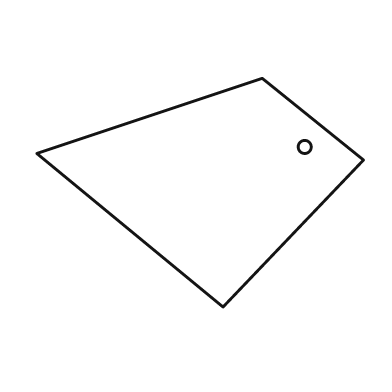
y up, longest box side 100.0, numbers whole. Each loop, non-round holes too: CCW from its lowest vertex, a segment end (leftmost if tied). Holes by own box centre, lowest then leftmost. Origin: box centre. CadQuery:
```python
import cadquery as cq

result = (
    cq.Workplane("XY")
    .moveTo(7.0, -35.0)
    .lineTo(50.0, 10.0)
    .lineTo(19.0, 35.0)
    .lineTo(-50.0, 12.0)
    .close()
    .moveTo(32.0, 14.0)
    .circle(2.0)
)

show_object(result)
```